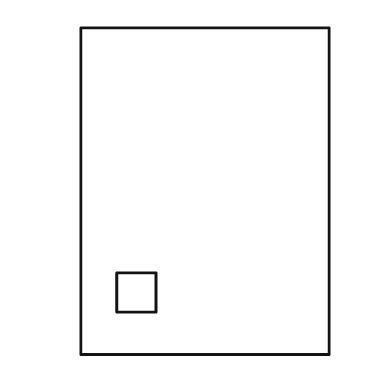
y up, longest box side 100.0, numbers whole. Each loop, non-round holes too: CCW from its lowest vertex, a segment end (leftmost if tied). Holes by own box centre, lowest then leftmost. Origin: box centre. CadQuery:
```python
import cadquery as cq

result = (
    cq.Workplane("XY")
    .moveTo(-38.0, -50.0)
    .lineTo(38.0, -50.0)
    .lineTo(38.0, 50.0)
    .lineTo(-38.0, 50.0)
    .close()
    .moveTo(-27.0, -37.0)
    .lineTo(-15.0, -37.0)
    .lineTo(-15.0, -25.0)
    .lineTo(-27.0, -25.0)
    .close()
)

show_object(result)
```